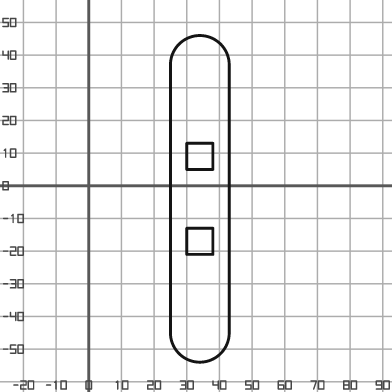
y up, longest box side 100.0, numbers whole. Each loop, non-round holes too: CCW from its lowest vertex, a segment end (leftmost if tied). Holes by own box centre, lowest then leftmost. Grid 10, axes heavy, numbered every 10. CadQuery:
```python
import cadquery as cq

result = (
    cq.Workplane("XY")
    .moveTo(25.0, -45.0)
    .threePointArc((34.0, -54.0), (43.0, -45.0))
    .lineTo(43.0, 37.0)
    .threePointArc((34.0, 46.0), (25.0, 37.0))
    .close()
    .moveTo(30.0, -21.0)
    .lineTo(38.0, -21.0)
    .lineTo(38.0, -13.0)
    .lineTo(30.0, -13.0)
    .close()
    .moveTo(30.0, 5.0)
    .lineTo(38.0, 5.0)
    .lineTo(38.0, 13.0)
    .lineTo(30.0, 13.0)
    .close()
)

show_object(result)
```